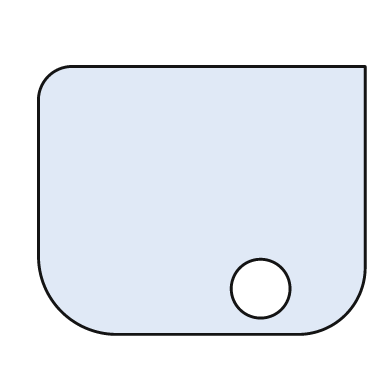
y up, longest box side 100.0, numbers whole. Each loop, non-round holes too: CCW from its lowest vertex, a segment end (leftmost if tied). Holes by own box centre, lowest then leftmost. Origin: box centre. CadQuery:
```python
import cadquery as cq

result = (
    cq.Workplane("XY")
    .moveTo(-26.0, -41.0)
    .lineTo(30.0, -41.0)
    .threePointArc((44.0, -35.0), (50.0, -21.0))
    .lineTo(50.0, 41.0)
    .lineTo(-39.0, 41.0)
    .threePointArc((-47.0, 38.0), (-50.0, 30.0))
    .lineTo(-50.0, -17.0)
    .threePointArc((-43.0, -34.0), (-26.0, -41.0))
    .close()
    .moveTo(18.0, -27.0)
    .circle(9.0)
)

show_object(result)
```